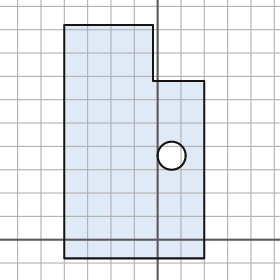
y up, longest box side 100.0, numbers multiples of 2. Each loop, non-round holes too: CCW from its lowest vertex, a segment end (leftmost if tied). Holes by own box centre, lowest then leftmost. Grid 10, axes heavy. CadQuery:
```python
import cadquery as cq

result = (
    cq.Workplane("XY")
    .moveTo(-40.0, -8.0)
    .lineTo(20.0, -8.0)
    .lineTo(20.0, 68.0)
    .lineTo(-2.0, 68.0)
    .lineTo(-2.0, 92.0)
    .lineTo(-40.0, 92.0)
    .close()
    .moveTo(6.0, 36.0)
    .circle(6.0)
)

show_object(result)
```